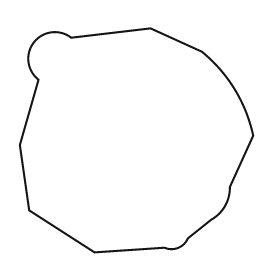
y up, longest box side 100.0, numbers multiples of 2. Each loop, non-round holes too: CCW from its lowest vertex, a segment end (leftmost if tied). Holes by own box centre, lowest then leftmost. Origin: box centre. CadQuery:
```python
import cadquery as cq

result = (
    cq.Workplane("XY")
    .moveTo(-18.0, -48.0)
    .lineTo(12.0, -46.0)
    .threePointArc((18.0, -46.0), (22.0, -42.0))
    .lineTo(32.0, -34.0)
    .threePointArc((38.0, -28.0), (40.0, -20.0))
    .lineTo(50.0, 2.0)
    .threePointArc((42.0, 22.0), (28.0, 38.0))
    .lineTo(6.0, 48.0)
    .lineTo(-28.0, 44.0)
    .threePointArc((-44.0, 42.0), (-42.0, 26.0))
    .lineTo(-50.0, -2.0)
    .lineTo(-46.0, -30.0)
    .close()
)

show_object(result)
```